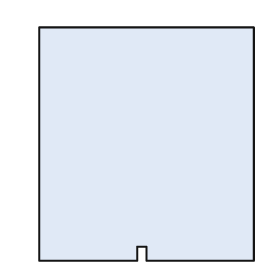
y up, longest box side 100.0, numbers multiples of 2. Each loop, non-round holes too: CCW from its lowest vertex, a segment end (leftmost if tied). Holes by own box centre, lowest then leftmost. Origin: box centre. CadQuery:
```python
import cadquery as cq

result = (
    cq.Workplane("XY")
    .moveTo(-46.0, -50.0)
    .lineTo(-4.0, -50.0)
    .lineTo(-4.0, -44.0)
    .lineTo(0.0, -44.0)
    .lineTo(0.0, -50.0)
    .lineTo(46.0, -50.0)
    .lineTo(46.0, 50.0)
    .lineTo(-46.0, 50.0)
    .close()
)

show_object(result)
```